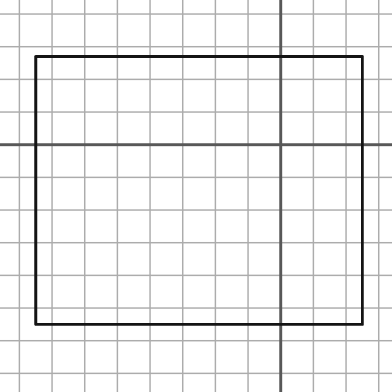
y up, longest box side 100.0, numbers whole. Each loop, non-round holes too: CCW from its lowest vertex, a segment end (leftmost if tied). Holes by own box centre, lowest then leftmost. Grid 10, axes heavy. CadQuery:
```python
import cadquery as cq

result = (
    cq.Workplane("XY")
    .moveTo(-75.0, -55.0)
    .lineTo(25.0, -55.0)
    .lineTo(25.0, 27.0)
    .lineTo(-75.0, 27.0)
    .close()
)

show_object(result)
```